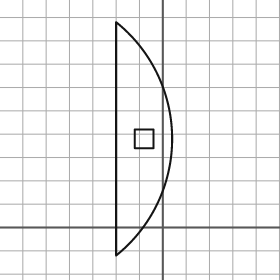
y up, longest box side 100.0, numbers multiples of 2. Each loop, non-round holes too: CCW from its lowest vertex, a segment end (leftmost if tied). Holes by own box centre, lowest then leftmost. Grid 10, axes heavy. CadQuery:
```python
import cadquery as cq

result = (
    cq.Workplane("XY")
    .moveTo(-20.0, -12.0)
    .threePointArc((4.0, 38.0), (-20.0, 88.0))
    .close()
    .moveTo(-12.0, 34.0)
    .lineTo(-4.0, 34.0)
    .lineTo(-4.0, 42.0)
    .lineTo(-12.0, 42.0)
    .close()
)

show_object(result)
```